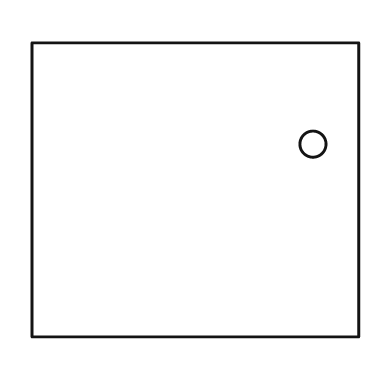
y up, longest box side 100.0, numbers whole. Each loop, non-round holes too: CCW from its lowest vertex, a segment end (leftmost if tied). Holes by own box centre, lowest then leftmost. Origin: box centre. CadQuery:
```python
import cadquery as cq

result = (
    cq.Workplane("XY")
    .moveTo(-50.0, -45.0)
    .lineTo(50.0, -45.0)
    .lineTo(50.0, 45.0)
    .lineTo(-50.0, 45.0)
    .close()
    .moveTo(36.0, 14.0)
    .circle(4.0)
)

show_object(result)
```